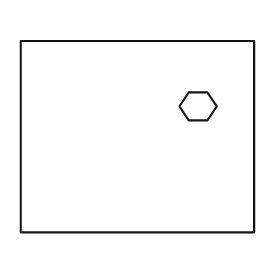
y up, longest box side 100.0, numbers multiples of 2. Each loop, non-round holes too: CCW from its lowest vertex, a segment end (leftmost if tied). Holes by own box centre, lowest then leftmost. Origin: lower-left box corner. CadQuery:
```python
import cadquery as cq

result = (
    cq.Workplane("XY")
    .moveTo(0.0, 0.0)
    .lineTo(100.0, 0.0)
    .lineTo(100.0, 82.0)
    .lineTo(0.0, 82.0)
    .close()
    .moveTo(72.0, 48.0)
    .lineTo(80.0, 48.0)
    .lineTo(84.0, 54.0)
    .lineTo(80.0, 60.0)
    .lineTo(72.0, 60.0)
    .lineTo(68.0, 54.0)
    .close()
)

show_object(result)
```